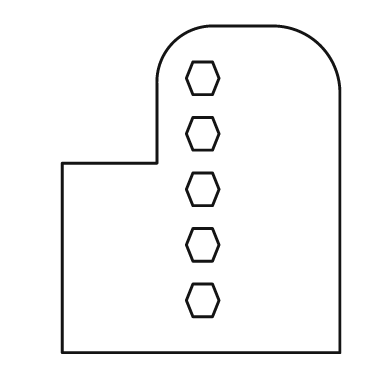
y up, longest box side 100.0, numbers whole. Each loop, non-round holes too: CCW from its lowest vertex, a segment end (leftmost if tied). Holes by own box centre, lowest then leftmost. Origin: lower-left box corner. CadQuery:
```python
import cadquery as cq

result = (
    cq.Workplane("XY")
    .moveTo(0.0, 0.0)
    .lineTo(85.0, 0.0)
    .lineTo(85.0, 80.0)
    .threePointArc((79.0, 94.0), (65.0, 100.0))
    .lineTo(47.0, 100.0)
    .threePointArc((34.0, 95.0), (29.0, 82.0))
    .lineTo(29.0, 58.0)
    .lineTo(0.0, 58.0)
    .close()
    .moveTo(40.0, 11.0)
    .lineTo(46.0, 11.0)
    .lineTo(48.0, 16.0)
    .lineTo(46.0, 21.0)
    .lineTo(40.0, 21.0)
    .lineTo(38.0, 16.0)
    .close()
    .moveTo(40.0, 28.0)
    .lineTo(46.0, 28.0)
    .lineTo(48.0, 33.0)
    .lineTo(46.0, 38.0)
    .lineTo(40.0, 38.0)
    .lineTo(38.0, 33.0)
    .close()
    .moveTo(40.0, 45.0)
    .lineTo(46.0, 45.0)
    .lineTo(48.0, 50.0)
    .lineTo(46.0, 55.0)
    .lineTo(40.0, 55.0)
    .lineTo(38.0, 50.0)
    .close()
    .moveTo(40.0, 62.0)
    .lineTo(46.0, 62.0)
    .lineTo(48.0, 67.0)
    .lineTo(46.0, 72.0)
    .lineTo(40.0, 72.0)
    .lineTo(38.0, 67.0)
    .close()
    .moveTo(40.0, 79.0)
    .lineTo(46.0, 79.0)
    .lineTo(48.0, 84.0)
    .lineTo(46.0, 89.0)
    .lineTo(40.0, 89.0)
    .lineTo(38.0, 84.0)
    .close()
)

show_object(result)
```